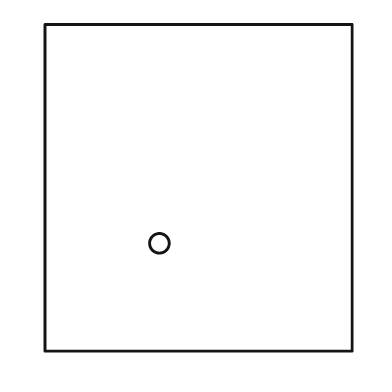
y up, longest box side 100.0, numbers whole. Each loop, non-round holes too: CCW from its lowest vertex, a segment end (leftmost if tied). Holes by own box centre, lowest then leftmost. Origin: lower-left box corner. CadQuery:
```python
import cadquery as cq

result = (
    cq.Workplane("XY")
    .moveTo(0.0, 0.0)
    .lineTo(94.0, 0.0)
    .lineTo(94.0, 100.0)
    .lineTo(0.0, 100.0)
    .close()
    .moveTo(35.0, 33.0)
    .circle(3.0)
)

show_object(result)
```